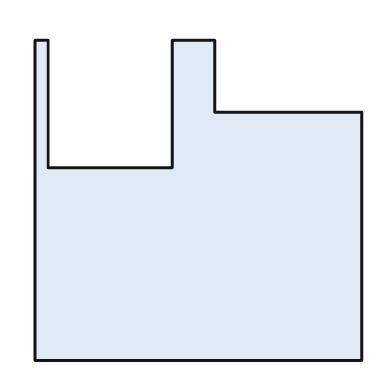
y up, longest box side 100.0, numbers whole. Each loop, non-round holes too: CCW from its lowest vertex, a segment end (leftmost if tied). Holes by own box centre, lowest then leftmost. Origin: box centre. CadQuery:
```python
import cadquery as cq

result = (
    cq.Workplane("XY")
    .moveTo(-50.0, -49.0)
    .lineTo(50.0, -49.0)
    .lineTo(50.0, 27.0)
    .lineTo(5.0, 27.0)
    .lineTo(5.0, 49.0)
    .lineTo(-8.0, 49.0)
    .lineTo(-8.0, 10.0)
    .lineTo(-46.0, 10.0)
    .lineTo(-46.0, 49.0)
    .lineTo(-50.0, 49.0)
    .close()
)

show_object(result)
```